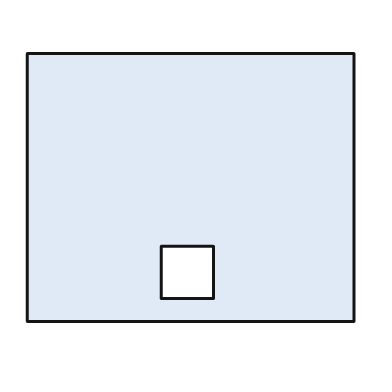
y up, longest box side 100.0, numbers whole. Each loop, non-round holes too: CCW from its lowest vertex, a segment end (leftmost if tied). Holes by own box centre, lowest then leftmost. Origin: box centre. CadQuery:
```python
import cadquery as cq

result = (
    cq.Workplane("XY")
    .moveTo(-50.0, -41.0)
    .lineTo(50.0, -41.0)
    .lineTo(50.0, 41.0)
    .lineTo(-50.0, 41.0)
    .close()
    .moveTo(-9.0, -34.0)
    .lineTo(7.0, -34.0)
    .lineTo(7.0, -18.0)
    .lineTo(-9.0, -18.0)
    .close()
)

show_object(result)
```